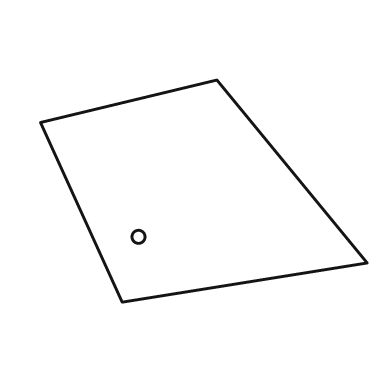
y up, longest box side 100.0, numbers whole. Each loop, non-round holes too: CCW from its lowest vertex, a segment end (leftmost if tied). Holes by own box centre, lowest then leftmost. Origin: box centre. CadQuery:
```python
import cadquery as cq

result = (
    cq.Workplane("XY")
    .moveTo(-25.0, -34.0)
    .lineTo(50.0, -22.0)
    .lineTo(4.0, 34.0)
    .lineTo(-50.0, 21.0)
    .close()
    .moveTo(-20.0, -14.0)
    .circle(2.0)
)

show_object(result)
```